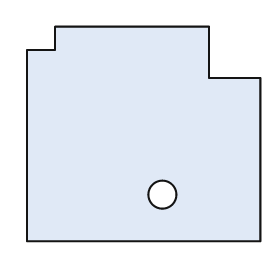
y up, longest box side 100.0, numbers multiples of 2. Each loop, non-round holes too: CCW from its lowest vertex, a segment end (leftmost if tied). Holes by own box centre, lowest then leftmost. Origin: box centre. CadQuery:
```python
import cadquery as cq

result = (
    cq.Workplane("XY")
    .moveTo(-50.0, -46.0)
    .lineTo(50.0, -46.0)
    .lineTo(50.0, 24.0)
    .lineTo(28.0, 24.0)
    .lineTo(28.0, 46.0)
    .lineTo(-38.0, 46.0)
    .lineTo(-38.0, 36.0)
    .lineTo(-50.0, 36.0)
    .close()
    .moveTo(8.0, -26.0)
    .circle(6.0)
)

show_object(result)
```